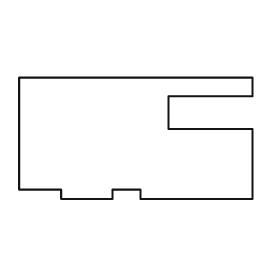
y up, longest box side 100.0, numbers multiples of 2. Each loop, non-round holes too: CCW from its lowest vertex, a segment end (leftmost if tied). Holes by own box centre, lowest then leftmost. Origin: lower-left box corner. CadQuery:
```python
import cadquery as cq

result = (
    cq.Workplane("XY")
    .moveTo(18.0, 0.0)
    .lineTo(40.0, 0.0)
    .lineTo(40.0, 4.0)
    .lineTo(52.0, 4.0)
    .lineTo(52.0, 0.0)
    .lineTo(100.0, 0.0)
    .lineTo(100.0, 30.0)
    .lineTo(64.0, 30.0)
    .lineTo(64.0, 44.0)
    .lineTo(100.0, 44.0)
    .lineTo(100.0, 52.0)
    .lineTo(0.0, 52.0)
    .lineTo(0.0, 4.0)
    .lineTo(18.0, 4.0)
    .close()
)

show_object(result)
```